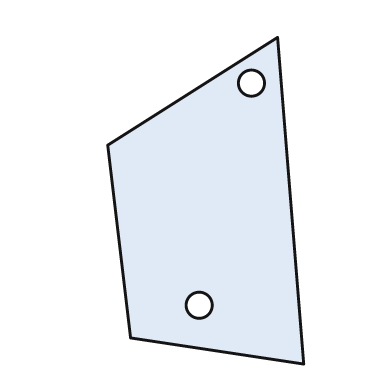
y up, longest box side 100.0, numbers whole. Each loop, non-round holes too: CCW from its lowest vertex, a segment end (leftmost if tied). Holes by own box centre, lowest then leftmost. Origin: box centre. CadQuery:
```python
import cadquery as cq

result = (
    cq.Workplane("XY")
    .moveTo(30.0, -50.0)
    .lineTo(22.0, 50.0)
    .lineTo(-30.0, 17.0)
    .lineTo(-23.0, -42.0)
    .close()
    .moveTo(-2.0, -32.0)
    .circle(4.0)
    .moveTo(14.0, 36.0)
    .circle(4.0)
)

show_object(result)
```